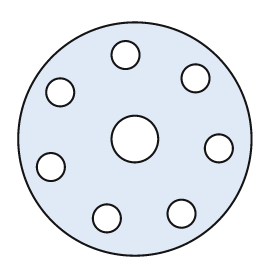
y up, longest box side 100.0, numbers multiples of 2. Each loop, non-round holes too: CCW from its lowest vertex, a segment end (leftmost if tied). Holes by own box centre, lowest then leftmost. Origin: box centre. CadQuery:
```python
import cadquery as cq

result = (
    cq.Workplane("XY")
    .moveTo(0.0, 0.0)
    .circle(50.0)
    .moveTo(-12.0, -34.0)
    .circle(6.0)
    .moveTo(20.0, -32.0)
    .circle(6.0)
    .moveTo(-36.0, -12.0)
    .circle(6.0)
    .moveTo(36.0, -4.0)
    .circle(6.0)
    .moveTo(0.0, 0.0)
    .circle(10.0)
    .moveTo(-32.0, 20.0)
    .circle(6.0)
    .moveTo(26.0, 26.0)
    .circle(6.0)
    .moveTo(-4.0, 36.0)
    .circle(6.0)
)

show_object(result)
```